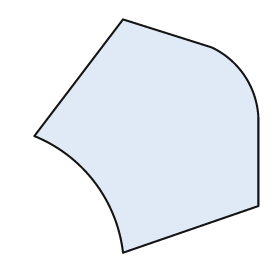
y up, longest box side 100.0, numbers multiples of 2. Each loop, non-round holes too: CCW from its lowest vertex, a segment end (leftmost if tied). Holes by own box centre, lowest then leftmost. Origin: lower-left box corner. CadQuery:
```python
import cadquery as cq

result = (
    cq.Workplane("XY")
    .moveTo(38.0, 0.0)
    .lineTo(96.0, 20.0)
    .lineTo(96.0, 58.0)
    .threePointArc((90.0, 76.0), (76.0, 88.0))
    .lineTo(38.0, 100.0)
    .lineTo(0.0, 50.0)
    .threePointArc((26.0, 30.0), (38.0, 0.0))
    .close()
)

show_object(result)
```